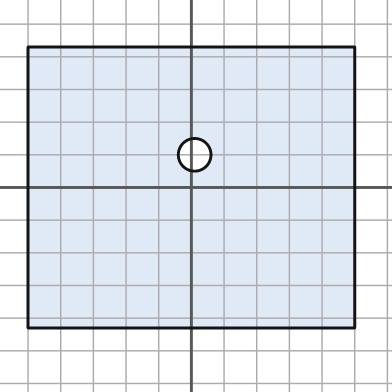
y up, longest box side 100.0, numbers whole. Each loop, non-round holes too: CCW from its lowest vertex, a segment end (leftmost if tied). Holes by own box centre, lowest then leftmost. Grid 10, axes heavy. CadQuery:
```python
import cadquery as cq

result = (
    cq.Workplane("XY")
    .moveTo(-50.0, -43.0)
    .lineTo(50.0, -43.0)
    .lineTo(50.0, 43.0)
    .lineTo(-50.0, 43.0)
    .close()
    .moveTo(1.0, 10.0)
    .circle(5.0)
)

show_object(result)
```